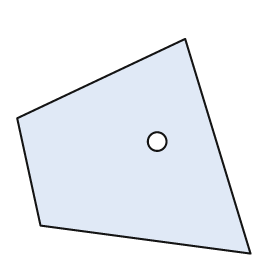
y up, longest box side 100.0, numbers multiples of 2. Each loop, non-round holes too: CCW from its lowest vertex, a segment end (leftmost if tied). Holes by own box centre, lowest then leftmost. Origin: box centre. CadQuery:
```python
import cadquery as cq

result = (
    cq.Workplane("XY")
    .moveTo(50.0, -46.0)
    .lineTo(22.0, 46.0)
    .lineTo(-50.0, 12.0)
    .lineTo(-40.0, -34.0)
    .close()
    .moveTo(10.0, 2.0)
    .circle(4.0)
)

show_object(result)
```